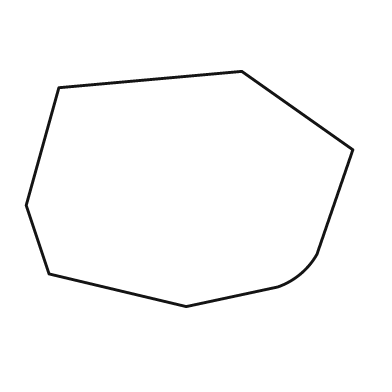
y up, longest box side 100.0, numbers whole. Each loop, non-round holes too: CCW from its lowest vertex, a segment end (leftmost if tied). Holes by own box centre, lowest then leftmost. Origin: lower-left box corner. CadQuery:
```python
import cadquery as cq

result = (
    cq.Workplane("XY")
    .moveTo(49.0, 0.0)
    .lineTo(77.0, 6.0)
    .threePointArc((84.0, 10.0), (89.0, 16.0))
    .lineTo(100.0, 48.0)
    .lineTo(66.0, 72.0)
    .lineTo(10.0, 67.0)
    .lineTo(0.0, 31.0)
    .lineTo(7.0, 10.0)
    .close()
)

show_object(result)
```